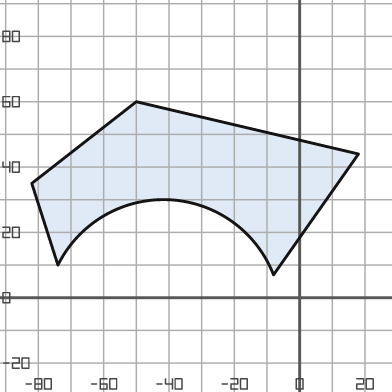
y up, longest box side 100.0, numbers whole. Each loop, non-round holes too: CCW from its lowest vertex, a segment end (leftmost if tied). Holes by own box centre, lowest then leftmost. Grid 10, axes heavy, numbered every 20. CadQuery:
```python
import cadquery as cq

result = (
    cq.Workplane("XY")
    .moveTo(-8.0, 7.0)
    .lineTo(18.0, 44.0)
    .lineTo(-50.0, 60.0)
    .lineTo(-82.0, 35.0)
    .lineTo(-74.0, 10.0)
    .threePointArc((-40.0, 30.0), (-8.0, 7.0))
    .close()
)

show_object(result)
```